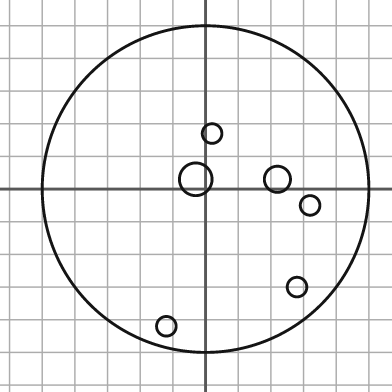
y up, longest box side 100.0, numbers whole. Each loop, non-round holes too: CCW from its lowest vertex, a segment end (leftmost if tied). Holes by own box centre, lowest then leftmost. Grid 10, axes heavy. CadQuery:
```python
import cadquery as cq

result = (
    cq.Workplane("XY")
    .moveTo(0.0, 0.0)
    .circle(50.0)
    .moveTo(-12.0, -42.0)
    .circle(3.0)
    .moveTo(28.0, -30.0)
    .circle(3.0)
    .moveTo(32.0, -5.0)
    .circle(3.0)
    .moveTo(-3.0, 3.0)
    .circle(5.0)
    .moveTo(22.0, 3.0)
    .circle(4.0)
    .moveTo(2.0, 17.0)
    .circle(3.0)
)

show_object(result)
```